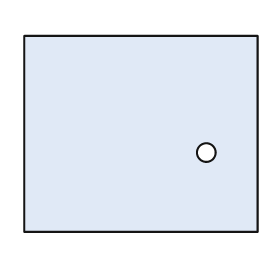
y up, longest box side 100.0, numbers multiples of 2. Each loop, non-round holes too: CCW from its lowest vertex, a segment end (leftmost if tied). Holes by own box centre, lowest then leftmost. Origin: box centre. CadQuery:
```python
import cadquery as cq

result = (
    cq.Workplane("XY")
    .moveTo(-50.0, -42.0)
    .lineTo(50.0, -42.0)
    .lineTo(50.0, 42.0)
    .lineTo(-50.0, 42.0)
    .close()
    .moveTo(28.0, -8.0)
    .circle(4.0)
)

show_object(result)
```